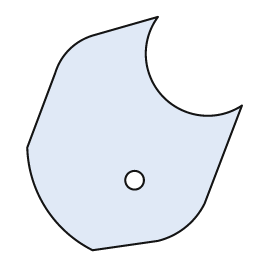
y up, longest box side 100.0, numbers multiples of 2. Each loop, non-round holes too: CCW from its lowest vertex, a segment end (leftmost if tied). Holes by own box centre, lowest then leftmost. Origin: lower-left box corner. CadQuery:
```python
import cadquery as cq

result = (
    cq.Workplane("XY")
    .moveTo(28.0, 0.0)
    .lineTo(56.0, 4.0)
    .threePointArc((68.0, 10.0), (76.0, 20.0))
    .lineTo(92.0, 62.0)
    .threePointArc((58.0, 66.0), (56.0, 100.0))
    .lineTo(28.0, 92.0)
    .threePointArc((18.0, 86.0), (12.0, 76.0))
    .lineTo(0.0, 44.0)
    .threePointArc((8.0, 18.0), (28.0, 0.0))
    .close()
    .moveTo(46.0, 30.0)
    .circle(4.0)
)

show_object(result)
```